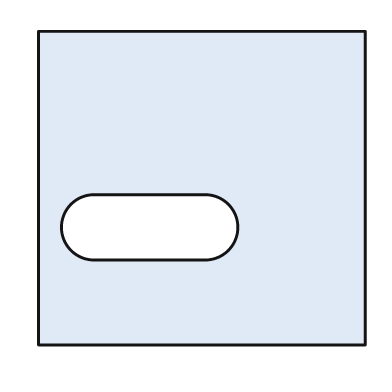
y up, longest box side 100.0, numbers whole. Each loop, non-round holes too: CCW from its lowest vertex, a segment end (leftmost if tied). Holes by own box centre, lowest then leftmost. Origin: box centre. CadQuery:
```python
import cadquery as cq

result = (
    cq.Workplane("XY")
    .moveTo(-50.0, -48.0)
    .lineTo(50.0, -48.0)
    .lineTo(50.0, 48.0)
    .lineTo(-50.0, 48.0)
    .close()
    .moveTo(-33.0, -22.0)
    .lineTo(1.0, -22.0)
    .threePointArc((11.0, -12.0), (1.0, -2.0))
    .lineTo(-33.0, -2.0)
    .threePointArc((-43.0, -12.0), (-33.0, -22.0))
    .close()
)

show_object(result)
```